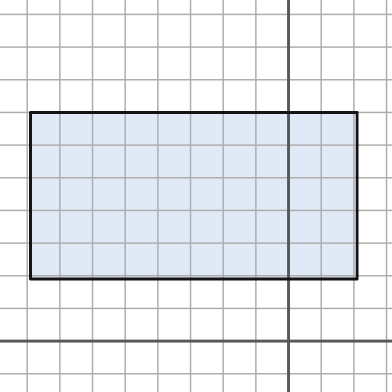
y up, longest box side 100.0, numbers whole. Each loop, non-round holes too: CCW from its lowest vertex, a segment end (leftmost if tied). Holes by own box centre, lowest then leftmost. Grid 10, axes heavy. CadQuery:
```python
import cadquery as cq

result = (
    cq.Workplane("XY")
    .moveTo(-79.0, 19.0)
    .lineTo(21.0, 19.0)
    .lineTo(21.0, 70.0)
    .lineTo(-79.0, 70.0)
    .close()
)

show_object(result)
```